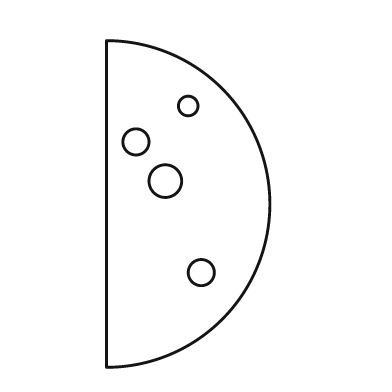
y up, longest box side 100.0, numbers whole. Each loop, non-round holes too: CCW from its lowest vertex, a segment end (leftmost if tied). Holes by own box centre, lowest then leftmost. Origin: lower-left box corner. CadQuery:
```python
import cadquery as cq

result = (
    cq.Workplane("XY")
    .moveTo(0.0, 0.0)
    .threePointArc((50.0, 50.0), (0.0, 100.0))
    .close()
    .moveTo(29.0, 29.0)
    .circle(4.0)
    .moveTo(18.0, 57.0)
    .circle(5.0)
    .moveTo(9.0, 69.0)
    .circle(4.0)
    .moveTo(25.0, 80.0)
    .circle(3.0)
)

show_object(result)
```